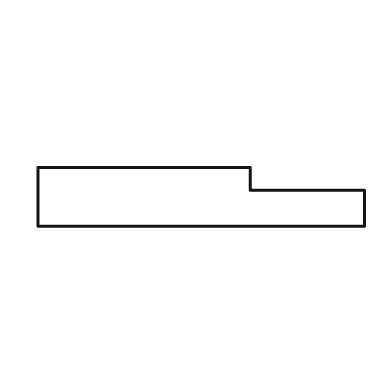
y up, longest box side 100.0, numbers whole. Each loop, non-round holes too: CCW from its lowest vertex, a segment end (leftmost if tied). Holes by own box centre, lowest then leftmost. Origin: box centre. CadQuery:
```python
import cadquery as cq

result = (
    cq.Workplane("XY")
    .moveTo(-50.0, -9.0)
    .lineTo(50.0, -9.0)
    .lineTo(50.0, 2.0)
    .lineTo(15.0, 2.0)
    .lineTo(15.0, 9.0)
    .lineTo(-50.0, 9.0)
    .close()
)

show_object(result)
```